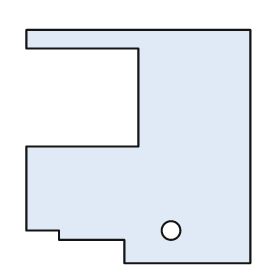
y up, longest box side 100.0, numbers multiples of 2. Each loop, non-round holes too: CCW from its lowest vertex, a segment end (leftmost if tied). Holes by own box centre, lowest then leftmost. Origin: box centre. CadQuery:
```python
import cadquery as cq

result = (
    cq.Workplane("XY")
    .moveTo(-6.0, -50.0)
    .lineTo(48.0, -50.0)
    .lineTo(48.0, 50.0)
    .lineTo(-48.0, 50.0)
    .lineTo(-48.0, 42.0)
    .lineTo(0.0, 42.0)
    .lineTo(0.0, 0.0)
    .lineTo(-48.0, 0.0)
    .lineTo(-48.0, -36.0)
    .lineTo(-34.0, -36.0)
    .lineTo(-34.0, -40.0)
    .lineTo(-6.0, -40.0)
    .close()
    .moveTo(14.0, -36.0)
    .circle(4.0)
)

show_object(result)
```